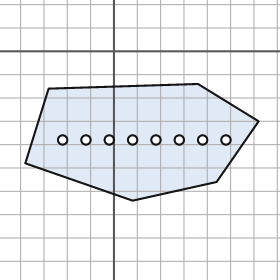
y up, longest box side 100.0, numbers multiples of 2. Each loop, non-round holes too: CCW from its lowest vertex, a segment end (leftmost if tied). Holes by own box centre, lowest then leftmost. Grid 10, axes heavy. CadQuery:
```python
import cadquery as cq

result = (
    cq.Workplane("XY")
    .moveTo(8.0, -64.0)
    .lineTo(44.0, -56.0)
    .lineTo(62.0, -30.0)
    .lineTo(36.0, -14.0)
    .lineTo(-28.0, -16.0)
    .lineTo(-38.0, -48.0)
    .close()
    .moveTo(-22.0, -38.0)
    .circle(2.0)
    .moveTo(-12.0, -38.0)
    .circle(2.0)
    .moveTo(-2.0, -38.0)
    .circle(2.0)
    .moveTo(8.0, -38.0)
    .circle(2.0)
    .moveTo(18.0, -38.0)
    .circle(2.0)
    .moveTo(28.0, -38.0)
    .circle(2.0)
    .moveTo(38.0, -38.0)
    .circle(2.0)
    .moveTo(48.0, -38.0)
    .circle(2.0)
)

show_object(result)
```